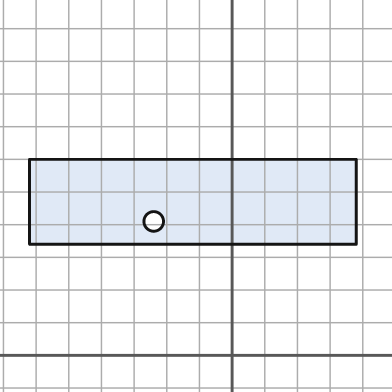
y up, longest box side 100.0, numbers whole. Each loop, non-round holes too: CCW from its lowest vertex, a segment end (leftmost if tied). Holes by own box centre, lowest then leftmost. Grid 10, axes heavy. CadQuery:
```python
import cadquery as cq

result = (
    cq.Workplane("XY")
    .moveTo(-62.0, 34.0)
    .lineTo(38.0, 34.0)
    .lineTo(38.0, 60.0)
    .lineTo(-62.0, 60.0)
    .close()
    .moveTo(-24.0, 41.0)
    .circle(3.0)
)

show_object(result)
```